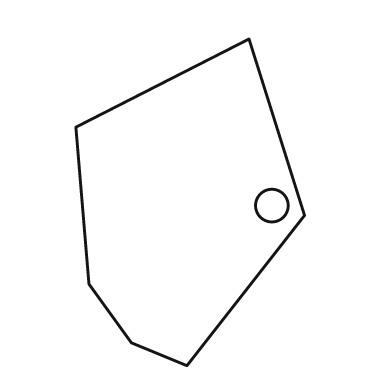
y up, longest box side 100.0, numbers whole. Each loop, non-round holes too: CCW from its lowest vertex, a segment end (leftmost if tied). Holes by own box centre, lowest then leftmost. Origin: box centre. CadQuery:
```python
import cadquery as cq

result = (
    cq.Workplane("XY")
    .moveTo(-1.0, -50.0)
    .lineTo(35.0, -4.0)
    .lineTo(18.0, 50.0)
    .lineTo(-35.0, 23.0)
    .lineTo(-31.0, -25.0)
    .lineTo(-18.0, -43.0)
    .close()
    .moveTo(25.0, -1.0)
    .circle(5.0)
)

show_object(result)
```